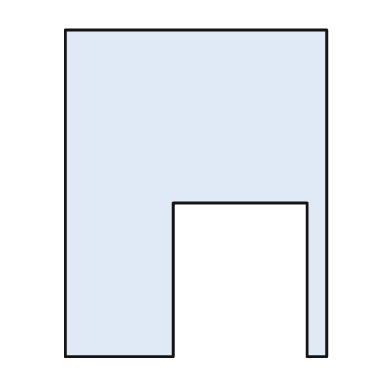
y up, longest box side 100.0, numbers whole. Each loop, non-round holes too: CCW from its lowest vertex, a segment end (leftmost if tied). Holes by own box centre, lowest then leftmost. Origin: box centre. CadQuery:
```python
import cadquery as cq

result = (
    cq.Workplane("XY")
    .moveTo(-40.0, -50.0)
    .lineTo(-7.0, -50.0)
    .lineTo(-7.0, -3.0)
    .lineTo(34.0, -3.0)
    .lineTo(34.0, -50.0)
    .lineTo(40.0, -50.0)
    .lineTo(40.0, 50.0)
    .lineTo(-40.0, 50.0)
    .close()
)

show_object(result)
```